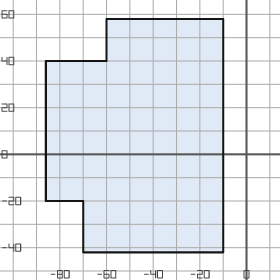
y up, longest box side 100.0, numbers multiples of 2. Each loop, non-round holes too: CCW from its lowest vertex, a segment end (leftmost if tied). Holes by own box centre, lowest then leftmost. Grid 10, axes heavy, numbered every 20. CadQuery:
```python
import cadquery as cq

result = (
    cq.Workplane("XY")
    .moveTo(-70.0, -42.0)
    .lineTo(-10.0, -42.0)
    .lineTo(-10.0, 58.0)
    .lineTo(-60.0, 58.0)
    .lineTo(-60.0, 40.0)
    .lineTo(-86.0, 40.0)
    .lineTo(-86.0, -20.0)
    .lineTo(-70.0, -20.0)
    .close()
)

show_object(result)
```